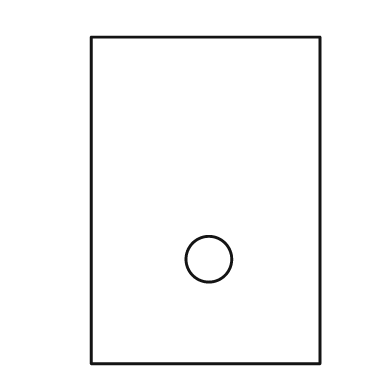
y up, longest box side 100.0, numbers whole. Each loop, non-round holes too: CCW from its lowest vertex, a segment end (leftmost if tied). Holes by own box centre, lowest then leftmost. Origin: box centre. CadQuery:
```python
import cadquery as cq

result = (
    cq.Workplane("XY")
    .moveTo(-35.0, -50.0)
    .lineTo(35.0, -50.0)
    .lineTo(35.0, 50.0)
    .lineTo(-35.0, 50.0)
    .close()
    .moveTo(1.0, -18.0)
    .circle(7.0)
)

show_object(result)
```